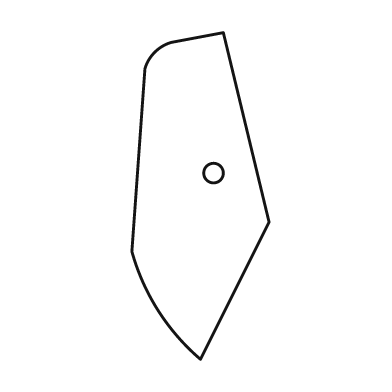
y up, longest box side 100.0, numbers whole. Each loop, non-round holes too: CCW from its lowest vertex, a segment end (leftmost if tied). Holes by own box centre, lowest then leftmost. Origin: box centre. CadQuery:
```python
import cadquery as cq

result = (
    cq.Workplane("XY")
    .moveTo(0.0, -50.0)
    .lineTo(21.0, -8.0)
    .lineTo(7.0, 50.0)
    .lineTo(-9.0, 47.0)
    .threePointArc((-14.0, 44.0), (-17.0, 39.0))
    .lineTo(-21.0, -17.0)
    .threePointArc((-13.0, -35.0), (0.0, -50.0))
    .close()
    .moveTo(4.0, 7.0)
    .circle(3.0)
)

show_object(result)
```